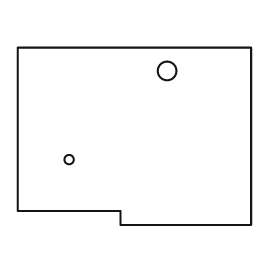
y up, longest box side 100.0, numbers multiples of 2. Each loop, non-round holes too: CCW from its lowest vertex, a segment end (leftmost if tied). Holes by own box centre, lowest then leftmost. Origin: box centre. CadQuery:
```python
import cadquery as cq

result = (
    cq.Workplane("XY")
    .moveTo(-6.0, -38.0)
    .lineTo(50.0, -38.0)
    .lineTo(50.0, 38.0)
    .lineTo(-50.0, 38.0)
    .lineTo(-50.0, -32.0)
    .lineTo(-6.0, -32.0)
    .close()
    .moveTo(-28.0, -10.0)
    .circle(2.0)
    .moveTo(14.0, 28.0)
    .circle(4.0)
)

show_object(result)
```